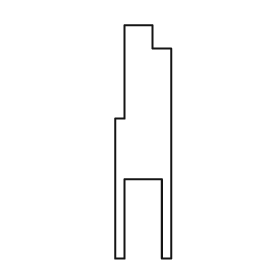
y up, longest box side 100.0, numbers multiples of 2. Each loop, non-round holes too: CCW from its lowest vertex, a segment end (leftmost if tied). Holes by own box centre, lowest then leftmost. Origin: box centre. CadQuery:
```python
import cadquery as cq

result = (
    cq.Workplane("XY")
    .moveTo(-12.0, -50.0)
    .lineTo(-8.0, -50.0)
    .lineTo(-8.0, -16.0)
    .lineTo(8.0, -16.0)
    .lineTo(8.0, -50.0)
    .lineTo(12.0, -50.0)
    .lineTo(12.0, 40.0)
    .lineTo(4.0, 40.0)
    .lineTo(4.0, 50.0)
    .lineTo(-8.0, 50.0)
    .lineTo(-8.0, 10.0)
    .lineTo(-12.0, 10.0)
    .close()
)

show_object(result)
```